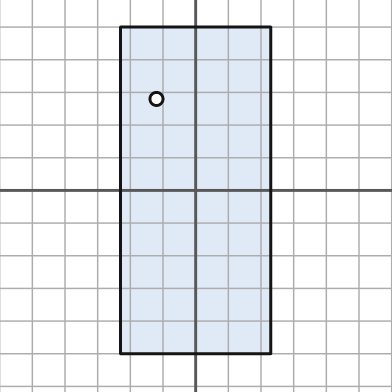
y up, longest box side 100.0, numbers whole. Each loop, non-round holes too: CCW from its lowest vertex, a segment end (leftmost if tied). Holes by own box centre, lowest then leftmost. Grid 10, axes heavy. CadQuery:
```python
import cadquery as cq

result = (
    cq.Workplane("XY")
    .moveTo(-23.0, -50.0)
    .lineTo(23.0, -50.0)
    .lineTo(23.0, 50.0)
    .lineTo(-23.0, 50.0)
    .close()
    .moveTo(-12.0, 28.0)
    .circle(2.0)
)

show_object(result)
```